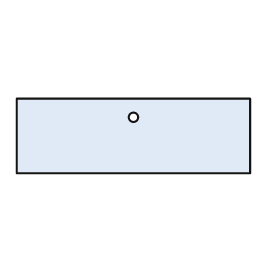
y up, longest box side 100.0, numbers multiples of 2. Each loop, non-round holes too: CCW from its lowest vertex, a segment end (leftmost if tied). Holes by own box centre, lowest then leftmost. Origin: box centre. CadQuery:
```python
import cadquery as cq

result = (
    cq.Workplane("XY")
    .moveTo(-50.0, -16.0)
    .lineTo(50.0, -16.0)
    .lineTo(50.0, 16.0)
    .lineTo(-50.0, 16.0)
    .close()
    .moveTo(0.0, 8.0)
    .circle(2.0)
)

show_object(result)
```